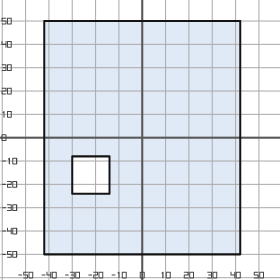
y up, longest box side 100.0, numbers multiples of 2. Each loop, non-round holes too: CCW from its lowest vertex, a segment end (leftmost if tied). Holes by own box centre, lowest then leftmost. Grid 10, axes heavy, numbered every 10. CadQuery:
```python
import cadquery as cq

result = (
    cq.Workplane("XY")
    .moveTo(-42.0, -50.0)
    .lineTo(42.0, -50.0)
    .lineTo(42.0, 50.0)
    .lineTo(-42.0, 50.0)
    .close()
    .moveTo(-30.0, -24.0)
    .lineTo(-14.0, -24.0)
    .lineTo(-14.0, -8.0)
    .lineTo(-30.0, -8.0)
    .close()
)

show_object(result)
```